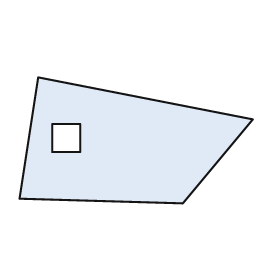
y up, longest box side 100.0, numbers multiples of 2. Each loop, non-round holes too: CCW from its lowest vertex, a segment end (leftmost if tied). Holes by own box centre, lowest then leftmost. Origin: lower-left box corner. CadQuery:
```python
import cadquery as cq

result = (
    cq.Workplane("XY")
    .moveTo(70.0, 0.0)
    .lineTo(100.0, 36.0)
    .lineTo(8.0, 54.0)
    .lineTo(0.0, 2.0)
    .close()
    .moveTo(14.0, 22.0)
    .lineTo(26.0, 22.0)
    .lineTo(26.0, 34.0)
    .lineTo(14.0, 34.0)
    .close()
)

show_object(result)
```